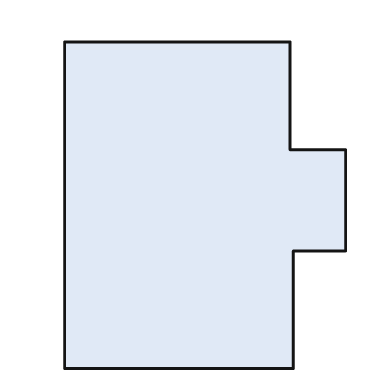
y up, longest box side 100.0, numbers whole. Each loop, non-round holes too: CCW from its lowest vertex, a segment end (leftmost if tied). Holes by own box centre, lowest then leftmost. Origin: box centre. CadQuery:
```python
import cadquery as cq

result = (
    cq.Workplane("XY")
    .moveTo(-43.0, -50.0)
    .lineTo(27.0, -50.0)
    .lineTo(27.0, -14.0)
    .lineTo(43.0, -14.0)
    .lineTo(43.0, 17.0)
    .lineTo(26.0, 17.0)
    .lineTo(26.0, 50.0)
    .lineTo(-43.0, 50.0)
    .close()
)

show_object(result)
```